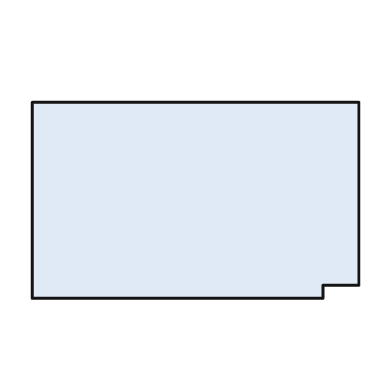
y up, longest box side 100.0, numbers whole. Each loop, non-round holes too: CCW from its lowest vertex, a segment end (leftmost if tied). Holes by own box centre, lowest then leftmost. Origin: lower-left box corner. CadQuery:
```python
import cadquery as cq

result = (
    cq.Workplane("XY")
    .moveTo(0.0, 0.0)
    .lineTo(89.0, 0.0)
    .lineTo(89.0, 4.0)
    .lineTo(100.0, 4.0)
    .lineTo(100.0, 60.0)
    .lineTo(0.0, 60.0)
    .close()
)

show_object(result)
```